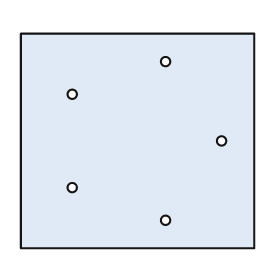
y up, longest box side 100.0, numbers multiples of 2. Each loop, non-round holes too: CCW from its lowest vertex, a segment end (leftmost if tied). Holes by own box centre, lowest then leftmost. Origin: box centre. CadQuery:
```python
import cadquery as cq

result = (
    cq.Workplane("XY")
    .moveTo(-50.0, -46.0)
    .lineTo(50.0, -46.0)
    .lineTo(50.0, 46.0)
    .lineTo(-50.0, 46.0)
    .close()
    .moveTo(12.0, -34.0)
    .circle(2.0)
    .moveTo(-28.0, -20.0)
    .circle(2.0)
    .moveTo(36.0, 0.0)
    .circle(2.0)
    .moveTo(-28.0, 20.0)
    .circle(2.0)
    .moveTo(12.0, 34.0)
    .circle(2.0)
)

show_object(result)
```